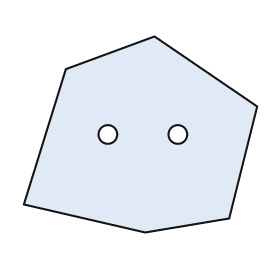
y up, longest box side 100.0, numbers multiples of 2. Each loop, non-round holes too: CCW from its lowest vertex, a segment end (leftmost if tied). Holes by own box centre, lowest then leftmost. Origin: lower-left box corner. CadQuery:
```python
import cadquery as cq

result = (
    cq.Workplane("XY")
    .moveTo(52.0, 0.0)
    .lineTo(88.0, 6.0)
    .lineTo(100.0, 54.0)
    .lineTo(56.0, 84.0)
    .lineTo(18.0, 70.0)
    .lineTo(0.0, 12.0)
    .close()
    .moveTo(36.0, 42.0)
    .circle(4.0)
    .moveTo(66.0, 42.0)
    .circle(4.0)
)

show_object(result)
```